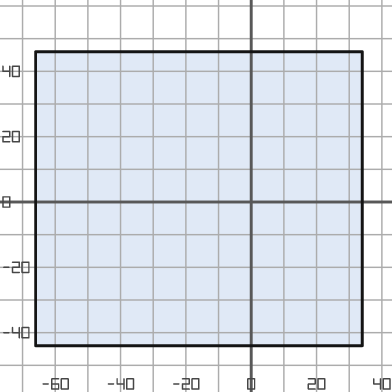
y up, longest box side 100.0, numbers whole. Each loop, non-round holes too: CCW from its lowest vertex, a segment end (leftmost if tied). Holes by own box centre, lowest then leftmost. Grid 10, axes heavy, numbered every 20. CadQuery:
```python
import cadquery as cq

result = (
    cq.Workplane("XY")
    .moveTo(-66.0, -44.0)
    .lineTo(34.0, -44.0)
    .lineTo(34.0, 46.0)
    .lineTo(-66.0, 46.0)
    .close()
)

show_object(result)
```